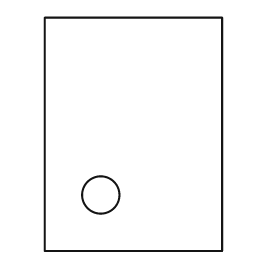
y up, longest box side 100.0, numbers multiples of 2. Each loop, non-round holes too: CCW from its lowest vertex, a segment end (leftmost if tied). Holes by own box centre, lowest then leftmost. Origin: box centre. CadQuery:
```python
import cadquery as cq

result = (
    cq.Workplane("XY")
    .moveTo(-38.0, -50.0)
    .lineTo(38.0, -50.0)
    .lineTo(38.0, 50.0)
    .lineTo(-38.0, 50.0)
    .close()
    .moveTo(-14.0, -26.0)
    .circle(8.0)
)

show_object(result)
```